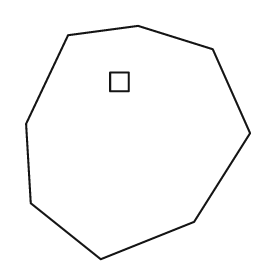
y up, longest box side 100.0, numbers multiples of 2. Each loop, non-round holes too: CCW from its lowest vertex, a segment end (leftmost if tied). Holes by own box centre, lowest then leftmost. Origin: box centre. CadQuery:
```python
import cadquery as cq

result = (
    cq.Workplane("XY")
    .moveTo(-16.0, -50.0)
    .lineTo(24.0, -34.0)
    .lineTo(48.0, 4.0)
    .lineTo(32.0, 40.0)
    .lineTo(0.0, 50.0)
    .lineTo(-30.0, 46.0)
    .lineTo(-48.0, 8.0)
    .lineTo(-46.0, -26.0)
    .close()
    .moveTo(-12.0, 22.0)
    .lineTo(-4.0, 22.0)
    .lineTo(-4.0, 30.0)
    .lineTo(-12.0, 30.0)
    .close()
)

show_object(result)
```